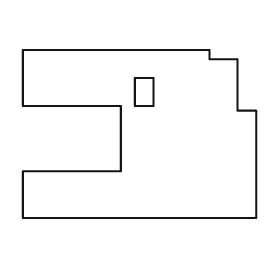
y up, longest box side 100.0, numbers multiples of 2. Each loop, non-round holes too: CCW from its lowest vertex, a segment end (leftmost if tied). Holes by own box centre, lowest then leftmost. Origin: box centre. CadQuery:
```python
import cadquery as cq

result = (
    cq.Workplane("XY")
    .moveTo(-50.0, -36.0)
    .lineTo(50.0, -36.0)
    .lineTo(50.0, 10.0)
    .lineTo(42.0, 10.0)
    .lineTo(42.0, 32.0)
    .lineTo(30.0, 32.0)
    .lineTo(30.0, 36.0)
    .lineTo(-50.0, 36.0)
    .lineTo(-50.0, 12.0)
    .lineTo(-8.0, 12.0)
    .lineTo(-8.0, -16.0)
    .lineTo(-50.0, -16.0)
    .close()
    .moveTo(-2.0, 12.0)
    .lineTo(6.0, 12.0)
    .lineTo(6.0, 24.0)
    .lineTo(-2.0, 24.0)
    .close()
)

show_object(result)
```